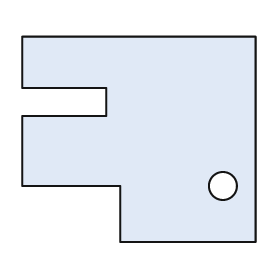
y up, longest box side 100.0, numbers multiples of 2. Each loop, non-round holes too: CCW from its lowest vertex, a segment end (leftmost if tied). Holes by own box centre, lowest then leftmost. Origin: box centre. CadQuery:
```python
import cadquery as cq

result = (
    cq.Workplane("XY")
    .moveTo(-8.0, -44.0)
    .lineTo(50.0, -44.0)
    .lineTo(50.0, 44.0)
    .lineTo(-50.0, 44.0)
    .lineTo(-50.0, 22.0)
    .lineTo(-14.0, 22.0)
    .lineTo(-14.0, 10.0)
    .lineTo(-50.0, 10.0)
    .lineTo(-50.0, -20.0)
    .lineTo(-8.0, -20.0)
    .close()
    .moveTo(36.0, -20.0)
    .circle(6.0)
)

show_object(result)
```